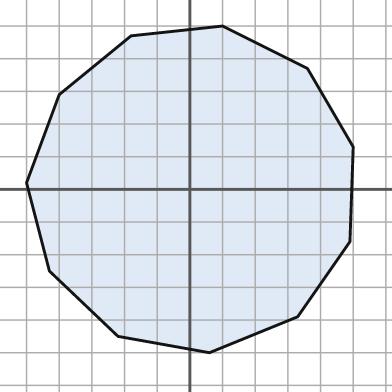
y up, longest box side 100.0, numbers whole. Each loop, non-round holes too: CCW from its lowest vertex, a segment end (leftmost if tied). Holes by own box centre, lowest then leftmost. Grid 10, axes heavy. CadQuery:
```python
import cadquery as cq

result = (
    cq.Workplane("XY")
    .moveTo(6.0, -50.0)
    .lineTo(33.0, -39.0)
    .lineTo(49.0, -16.0)
    .lineTo(50.0, 13.0)
    .lineTo(36.0, 37.0)
    .lineTo(10.0, 50.0)
    .lineTo(-18.0, 47.0)
    .lineTo(-40.0, 29.0)
    .lineTo(-50.0, 2.0)
    .lineTo(-43.0, -25.0)
    .lineTo(-22.0, -45.0)
    .close()
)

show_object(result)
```